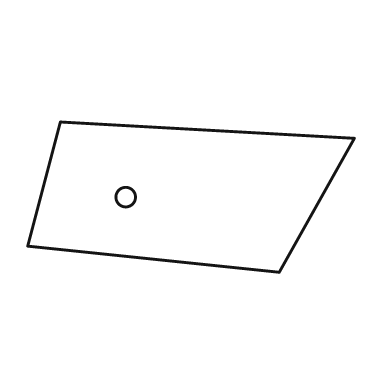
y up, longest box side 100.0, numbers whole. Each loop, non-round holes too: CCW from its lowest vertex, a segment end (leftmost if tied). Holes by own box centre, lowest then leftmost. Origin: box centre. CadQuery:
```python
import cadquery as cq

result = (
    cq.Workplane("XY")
    .moveTo(27.0, -23.0)
    .lineTo(50.0, 18.0)
    .lineTo(-40.0, 23.0)
    .lineTo(-50.0, -15.0)
    .close()
    .moveTo(-20.0, 0.0)
    .circle(3.0)
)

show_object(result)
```